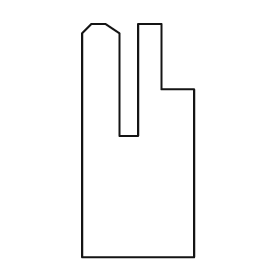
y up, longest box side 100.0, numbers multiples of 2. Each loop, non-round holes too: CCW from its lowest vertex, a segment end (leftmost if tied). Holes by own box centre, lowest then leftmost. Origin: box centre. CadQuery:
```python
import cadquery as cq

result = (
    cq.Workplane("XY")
    .moveTo(-24.0, -50.0)
    .lineTo(24.0, -50.0)
    .lineTo(24.0, 22.0)
    .lineTo(10.0, 22.0)
    .lineTo(10.0, 50.0)
    .lineTo(0.0, 50.0)
    .lineTo(0.0, 2.0)
    .lineTo(-8.0, 2.0)
    .lineTo(-8.0, 46.0)
    .lineTo(-14.0, 50.0)
    .lineTo(-20.0, 50.0)
    .lineTo(-24.0, 46.0)
    .close()
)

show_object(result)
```